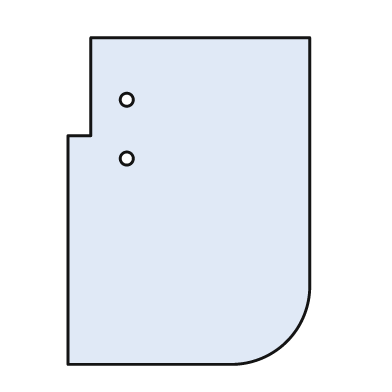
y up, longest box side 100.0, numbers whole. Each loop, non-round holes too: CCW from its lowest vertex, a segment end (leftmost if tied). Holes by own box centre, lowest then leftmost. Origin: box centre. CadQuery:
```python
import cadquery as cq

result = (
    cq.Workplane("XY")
    .moveTo(-37.0, -50.0)
    .lineTo(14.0, -50.0)
    .threePointArc((30.0, -43.0), (37.0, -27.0))
    .lineTo(37.0, 50.0)
    .lineTo(-30.0, 50.0)
    .lineTo(-30.0, 20.0)
    .lineTo(-37.0, 20.0)
    .close()
    .moveTo(-19.0, 13.0)
    .circle(2.0)
    .moveTo(-19.0, 31.0)
    .circle(2.0)
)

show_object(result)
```